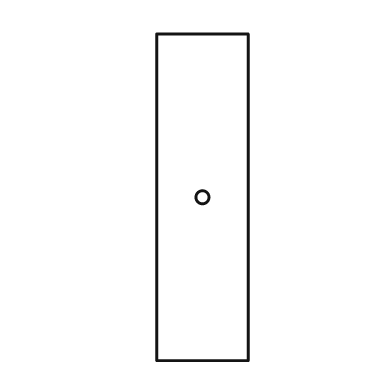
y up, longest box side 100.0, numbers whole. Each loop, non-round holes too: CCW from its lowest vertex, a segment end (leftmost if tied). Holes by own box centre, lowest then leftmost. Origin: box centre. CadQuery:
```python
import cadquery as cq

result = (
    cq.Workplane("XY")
    .moveTo(-14.0, -50.0)
    .lineTo(14.0, -50.0)
    .lineTo(14.0, 50.0)
    .lineTo(-14.0, 50.0)
    .close()
    .moveTo(0.0, 0.0)
    .circle(2.0)
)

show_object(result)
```